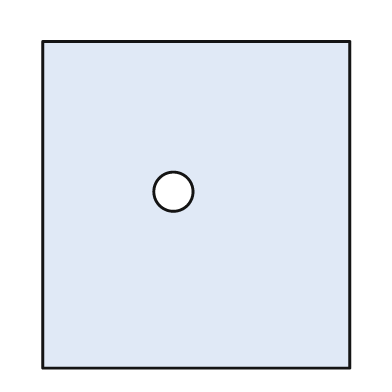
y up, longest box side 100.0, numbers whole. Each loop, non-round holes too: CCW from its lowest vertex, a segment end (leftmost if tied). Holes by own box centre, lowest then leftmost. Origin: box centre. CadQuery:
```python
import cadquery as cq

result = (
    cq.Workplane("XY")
    .moveTo(-47.0, -50.0)
    .lineTo(47.0, -50.0)
    .lineTo(47.0, 50.0)
    .lineTo(-47.0, 50.0)
    .close()
    .moveTo(-7.0, 4.0)
    .circle(6.0)
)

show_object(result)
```